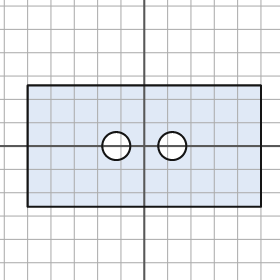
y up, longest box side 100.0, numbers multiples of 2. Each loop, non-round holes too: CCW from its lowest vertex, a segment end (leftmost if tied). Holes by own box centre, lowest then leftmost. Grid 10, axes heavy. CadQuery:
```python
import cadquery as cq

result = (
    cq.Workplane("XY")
    .moveTo(-50.0, -26.0)
    .lineTo(50.0, -26.0)
    .lineTo(50.0, 26.0)
    .lineTo(-50.0, 26.0)
    .close()
    .moveTo(-12.0, 0.0)
    .circle(6.0)
    .moveTo(12.0, 0.0)
    .circle(6.0)
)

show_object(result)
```